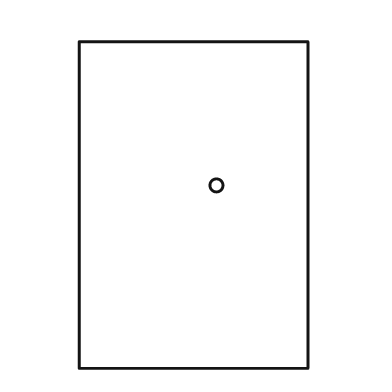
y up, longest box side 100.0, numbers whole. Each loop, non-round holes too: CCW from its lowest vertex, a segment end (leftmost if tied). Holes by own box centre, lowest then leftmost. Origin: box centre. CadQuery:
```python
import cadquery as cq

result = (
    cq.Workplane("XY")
    .moveTo(-35.0, -50.0)
    .lineTo(35.0, -50.0)
    .lineTo(35.0, 50.0)
    .lineTo(-35.0, 50.0)
    .close()
    .moveTo(7.0, 6.0)
    .circle(2.0)
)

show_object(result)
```